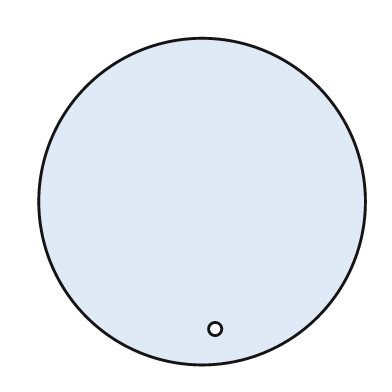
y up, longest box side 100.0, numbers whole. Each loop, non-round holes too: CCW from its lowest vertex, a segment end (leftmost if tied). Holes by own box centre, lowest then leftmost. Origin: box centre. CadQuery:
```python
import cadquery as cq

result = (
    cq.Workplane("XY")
    .moveTo(0.0, 0.0)
    .circle(50.0)
    .moveTo(4.0, -39.0)
    .circle(2.0)
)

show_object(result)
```